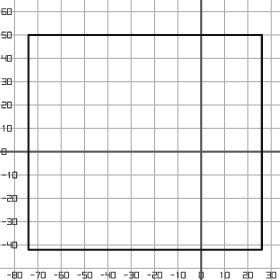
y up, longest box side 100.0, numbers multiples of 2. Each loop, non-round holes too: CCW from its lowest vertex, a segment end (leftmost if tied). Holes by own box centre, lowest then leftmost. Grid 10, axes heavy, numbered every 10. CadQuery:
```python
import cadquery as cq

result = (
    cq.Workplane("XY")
    .moveTo(-74.0, -42.0)
    .lineTo(26.0, -42.0)
    .lineTo(26.0, 50.0)
    .lineTo(-74.0, 50.0)
    .close()
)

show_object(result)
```